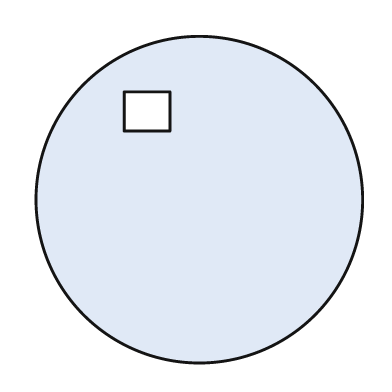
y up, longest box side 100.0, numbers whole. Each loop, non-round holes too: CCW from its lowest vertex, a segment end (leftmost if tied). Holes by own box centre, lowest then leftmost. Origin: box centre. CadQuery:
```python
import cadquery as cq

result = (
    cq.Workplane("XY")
    .moveTo(0.0, 0.0)
    .circle(50.0)
    .moveTo(-23.0, 21.0)
    .lineTo(-9.0, 21.0)
    .lineTo(-9.0, 33.0)
    .lineTo(-23.0, 33.0)
    .close()
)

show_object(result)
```